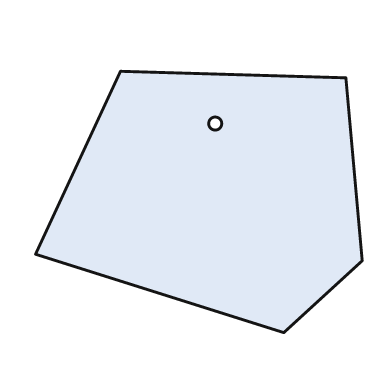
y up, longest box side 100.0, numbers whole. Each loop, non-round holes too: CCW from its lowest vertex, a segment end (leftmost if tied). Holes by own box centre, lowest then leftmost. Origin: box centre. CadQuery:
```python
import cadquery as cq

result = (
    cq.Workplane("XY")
    .moveTo(26.0, -40.0)
    .lineTo(50.0, -18.0)
    .lineTo(45.0, 38.0)
    .lineTo(-24.0, 40.0)
    .lineTo(-50.0, -16.0)
    .close()
    .moveTo(5.0, 24.0)
    .circle(2.0)
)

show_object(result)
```